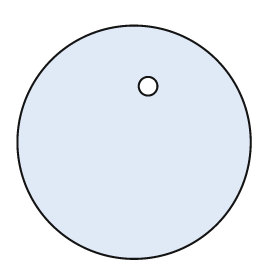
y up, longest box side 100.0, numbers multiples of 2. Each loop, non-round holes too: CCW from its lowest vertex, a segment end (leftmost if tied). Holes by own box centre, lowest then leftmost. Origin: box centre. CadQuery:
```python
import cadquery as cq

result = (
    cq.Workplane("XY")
    .moveTo(0.0, 0.0)
    .circle(50.0)
    .moveTo(6.0, 24.0)
    .circle(4.0)
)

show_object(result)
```